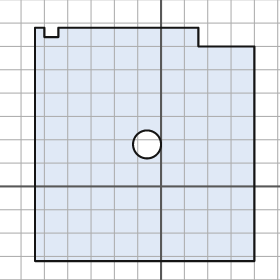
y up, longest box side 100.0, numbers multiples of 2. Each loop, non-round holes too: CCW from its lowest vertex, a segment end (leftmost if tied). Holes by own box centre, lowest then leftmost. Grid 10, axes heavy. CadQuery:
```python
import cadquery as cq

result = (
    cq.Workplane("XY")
    .moveTo(-54.0, -32.0)
    .lineTo(40.0, -32.0)
    .lineTo(40.0, 60.0)
    .lineTo(16.0, 60.0)
    .lineTo(16.0, 68.0)
    .lineTo(-44.0, 68.0)
    .lineTo(-44.0, 64.0)
    .lineTo(-50.0, 64.0)
    .lineTo(-50.0, 68.0)
    .lineTo(-54.0, 68.0)
    .close()
    .moveTo(-6.0, 18.0)
    .circle(6.0)
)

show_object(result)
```